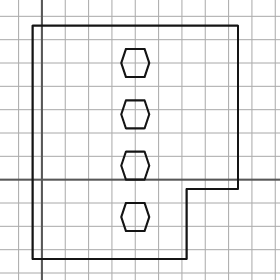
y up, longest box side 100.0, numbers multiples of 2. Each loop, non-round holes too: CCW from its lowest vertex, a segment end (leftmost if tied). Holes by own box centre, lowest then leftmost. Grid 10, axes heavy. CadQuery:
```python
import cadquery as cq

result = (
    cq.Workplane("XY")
    .moveTo(-4.0, -34.0)
    .lineTo(62.0, -34.0)
    .lineTo(62.0, -4.0)
    .lineTo(84.0, -4.0)
    .lineTo(84.0, 66.0)
    .lineTo(-4.0, 66.0)
    .close()
    .moveTo(36.0, -22.0)
    .lineTo(44.0, -22.0)
    .lineTo(46.0, -16.0)
    .lineTo(44.0, -10.0)
    .lineTo(36.0, -10.0)
    .lineTo(34.0, -16.0)
    .close()
    .moveTo(36.0, 0.0)
    .lineTo(44.0, 0.0)
    .lineTo(46.0, 6.0)
    .lineTo(44.0, 12.0)
    .lineTo(36.0, 12.0)
    .lineTo(34.0, 6.0)
    .close()
    .moveTo(36.0, 22.0)
    .lineTo(44.0, 22.0)
    .lineTo(46.0, 28.0)
    .lineTo(44.0, 34.0)
    .lineTo(36.0, 34.0)
    .lineTo(34.0, 28.0)
    .close()
    .moveTo(36.0, 44.0)
    .lineTo(44.0, 44.0)
    .lineTo(46.0, 50.0)
    .lineTo(44.0, 56.0)
    .lineTo(36.0, 56.0)
    .lineTo(34.0, 50.0)
    .close()
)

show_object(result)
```